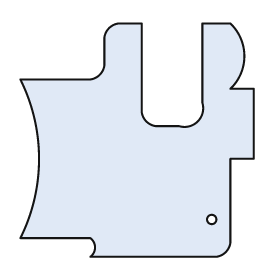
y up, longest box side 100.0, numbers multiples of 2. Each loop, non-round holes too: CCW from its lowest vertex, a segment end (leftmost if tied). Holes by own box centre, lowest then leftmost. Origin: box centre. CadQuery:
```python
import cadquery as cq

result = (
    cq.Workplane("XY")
    .moveTo(-20.0, -50.0)
    .lineTo(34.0, -50.0)
    .threePointArc((38.0, -48.0), (40.0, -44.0))
    .lineTo(40.0, -8.0)
    .lineTo(50.0, -8.0)
    .lineTo(50.0, 22.0)
    .lineTo(40.0, 22.0)
    .threePointArc((46.0, 36.0), (40.0, 50.0))
    .lineTo(28.0, 50.0)
    .lineTo(28.0, 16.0)
    .threePointArc((26.0, 8.0), (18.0, 6.0))
    .lineTo(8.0, 6.0)
    .threePointArc((4.0, 8.0), (2.0, 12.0))
    .lineTo(2.0, 50.0)
    .lineTo(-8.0, 50.0)
    .threePointArc((-12.0, 48.0), (-14.0, 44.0))
    .lineTo(-14.0, 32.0)
    .threePointArc((-16.0, 28.0), (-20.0, 26.0))
    .lineTo(-50.0, 26.0)
    .threePointArc((-42.0, -8.0), (-50.0, -42.0))
    .lineTo(-20.0, -42.0)
    .threePointArc((-18.0, -46.0), (-20.0, -50.0))
    .close()
    .moveTo(32.0, -34.0)
    .circle(2.0)
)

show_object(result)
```